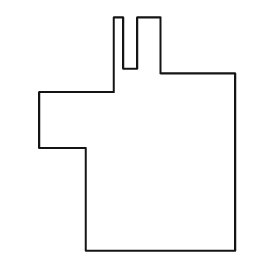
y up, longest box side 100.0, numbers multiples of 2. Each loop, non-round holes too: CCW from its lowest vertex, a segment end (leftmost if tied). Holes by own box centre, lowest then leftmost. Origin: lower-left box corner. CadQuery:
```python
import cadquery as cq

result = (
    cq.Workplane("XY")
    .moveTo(20.0, 0.0)
    .lineTo(84.0, 0.0)
    .lineTo(84.0, 76.0)
    .lineTo(52.0, 76.0)
    .lineTo(52.0, 100.0)
    .lineTo(42.0, 100.0)
    .lineTo(42.0, 78.0)
    .lineTo(36.0, 78.0)
    .lineTo(36.0, 100.0)
    .lineTo(32.0, 100.0)
    .lineTo(32.0, 68.0)
    .lineTo(0.0, 68.0)
    .lineTo(0.0, 44.0)
    .lineTo(20.0, 44.0)
    .close()
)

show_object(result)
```